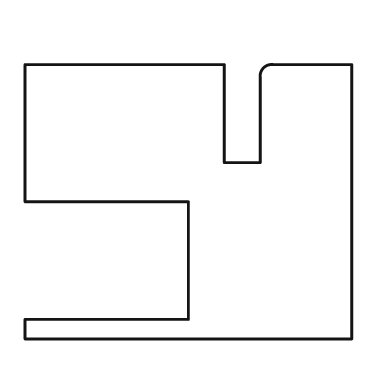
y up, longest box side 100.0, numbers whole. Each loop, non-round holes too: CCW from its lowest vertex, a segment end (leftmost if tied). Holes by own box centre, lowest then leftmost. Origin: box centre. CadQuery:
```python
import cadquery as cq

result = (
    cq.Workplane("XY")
    .moveTo(-50.0, -42.0)
    .lineTo(50.0, -42.0)
    .lineTo(50.0, 42.0)
    .lineTo(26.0, 42.0)
    .threePointArc((23.0, 41.0), (22.0, 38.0))
    .lineTo(22.0, 12.0)
    .lineTo(11.0, 12.0)
    .lineTo(11.0, 42.0)
    .lineTo(-50.0, 42.0)
    .lineTo(-50.0, 0.0)
    .lineTo(0.0, 0.0)
    .lineTo(0.0, -36.0)
    .lineTo(-50.0, -36.0)
    .close()
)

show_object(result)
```